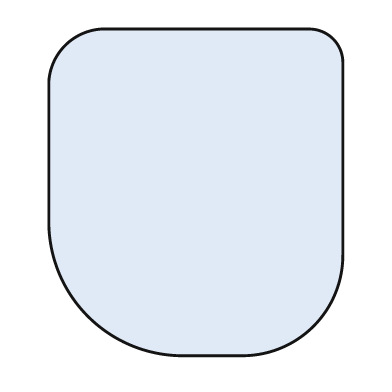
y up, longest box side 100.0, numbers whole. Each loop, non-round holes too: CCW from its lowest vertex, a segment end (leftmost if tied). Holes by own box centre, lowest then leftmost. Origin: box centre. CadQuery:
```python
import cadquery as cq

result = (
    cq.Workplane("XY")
    .moveTo(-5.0, -50.0)
    .lineTo(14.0, -50.0)
    .threePointArc((36.0, -41.0), (45.0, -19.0))
    .lineTo(45.0, 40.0)
    .threePointArc((42.0, 47.0), (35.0, 50.0))
    .lineTo(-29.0, 50.0)
    .threePointArc((-40.0, 45.0), (-45.0, 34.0))
    .lineTo(-45.0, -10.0)
    .threePointArc((-33.0, -38.0), (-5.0, -50.0))
    .close()
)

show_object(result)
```